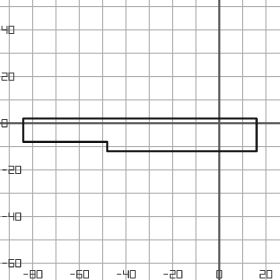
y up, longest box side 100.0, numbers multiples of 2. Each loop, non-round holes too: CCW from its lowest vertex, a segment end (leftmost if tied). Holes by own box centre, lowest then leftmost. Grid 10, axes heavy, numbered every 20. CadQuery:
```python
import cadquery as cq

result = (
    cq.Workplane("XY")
    .moveTo(-48.0, -12.0)
    .lineTo(16.0, -12.0)
    .lineTo(16.0, 2.0)
    .lineTo(-84.0, 2.0)
    .lineTo(-84.0, -8.0)
    .lineTo(-48.0, -8.0)
    .close()
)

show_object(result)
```